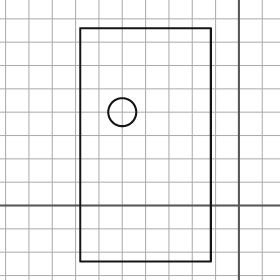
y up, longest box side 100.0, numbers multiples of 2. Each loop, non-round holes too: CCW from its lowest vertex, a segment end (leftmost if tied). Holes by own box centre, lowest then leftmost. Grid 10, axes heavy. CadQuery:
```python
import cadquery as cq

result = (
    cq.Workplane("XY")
    .moveTo(-68.0, -24.0)
    .lineTo(-12.0, -24.0)
    .lineTo(-12.0, 76.0)
    .lineTo(-68.0, 76.0)
    .close()
    .moveTo(-50.0, 40.0)
    .circle(6.0)
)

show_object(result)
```